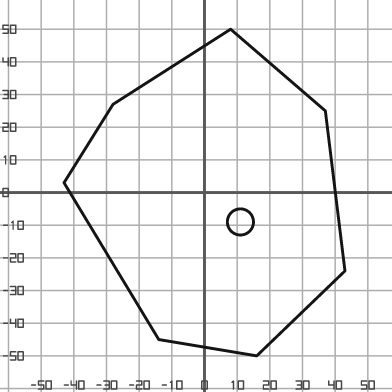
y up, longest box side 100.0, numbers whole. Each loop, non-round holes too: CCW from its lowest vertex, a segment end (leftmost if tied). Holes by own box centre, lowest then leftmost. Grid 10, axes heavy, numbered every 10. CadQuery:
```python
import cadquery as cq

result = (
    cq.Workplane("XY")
    .moveTo(16.0, -50.0)
    .lineTo(43.0, -24.0)
    .lineTo(37.0, 25.0)
    .lineTo(8.0, 50.0)
    .lineTo(-28.0, 27.0)
    .lineTo(-43.0, 3.0)
    .lineTo(-14.0, -45.0)
    .close()
    .moveTo(11.0, -9.0)
    .circle(4.0)
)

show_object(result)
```